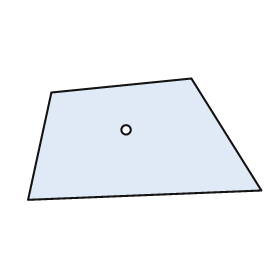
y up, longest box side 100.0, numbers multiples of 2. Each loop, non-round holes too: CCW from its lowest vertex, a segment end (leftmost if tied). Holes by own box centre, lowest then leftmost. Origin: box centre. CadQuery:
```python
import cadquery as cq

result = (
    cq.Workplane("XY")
    .moveTo(-50.0, -26.0)
    .lineTo(50.0, -22.0)
    .lineTo(20.0, 26.0)
    .lineTo(-40.0, 20.0)
    .close()
    .moveTo(-8.0, 4.0)
    .circle(2.0)
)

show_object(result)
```